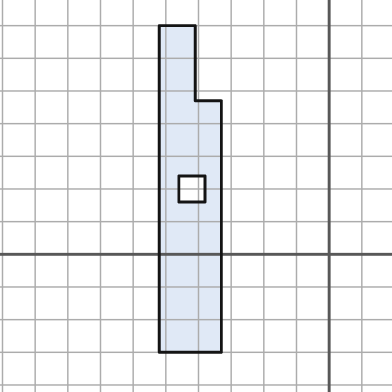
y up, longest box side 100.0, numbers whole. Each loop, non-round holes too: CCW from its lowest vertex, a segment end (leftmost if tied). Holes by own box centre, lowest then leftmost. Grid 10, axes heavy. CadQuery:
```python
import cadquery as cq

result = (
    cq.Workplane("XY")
    .moveTo(-52.0, -30.0)
    .lineTo(-33.0, -30.0)
    .lineTo(-33.0, 47.0)
    .lineTo(-41.0, 47.0)
    .lineTo(-41.0, 70.0)
    .lineTo(-52.0, 70.0)
    .close()
    .moveTo(-46.0, 16.0)
    .lineTo(-38.0, 16.0)
    .lineTo(-38.0, 24.0)
    .lineTo(-46.0, 24.0)
    .close()
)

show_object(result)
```